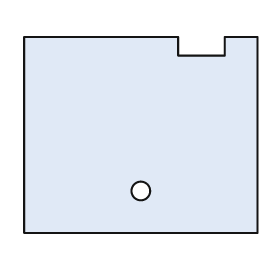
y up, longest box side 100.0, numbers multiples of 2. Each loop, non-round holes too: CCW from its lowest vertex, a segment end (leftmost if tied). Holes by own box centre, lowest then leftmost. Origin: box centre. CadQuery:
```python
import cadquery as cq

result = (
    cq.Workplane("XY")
    .moveTo(-50.0, -42.0)
    .lineTo(50.0, -42.0)
    .lineTo(50.0, 42.0)
    .lineTo(36.0, 42.0)
    .lineTo(36.0, 34.0)
    .lineTo(16.0, 34.0)
    .lineTo(16.0, 42.0)
    .lineTo(-50.0, 42.0)
    .close()
    .moveTo(0.0, -24.0)
    .circle(4.0)
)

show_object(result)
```